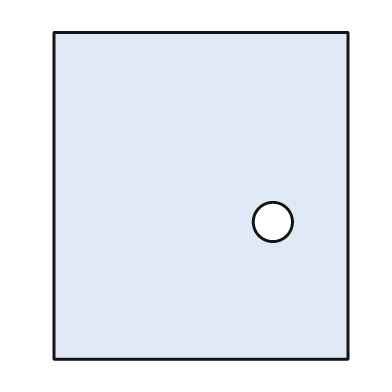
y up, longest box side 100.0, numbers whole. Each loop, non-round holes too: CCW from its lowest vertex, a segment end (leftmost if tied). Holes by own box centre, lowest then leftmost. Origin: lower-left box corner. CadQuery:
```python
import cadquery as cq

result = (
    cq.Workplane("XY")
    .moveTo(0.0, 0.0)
    .lineTo(90.0, 0.0)
    .lineTo(90.0, 100.0)
    .lineTo(0.0, 100.0)
    .close()
    .moveTo(67.0, 42.0)
    .circle(6.0)
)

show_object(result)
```